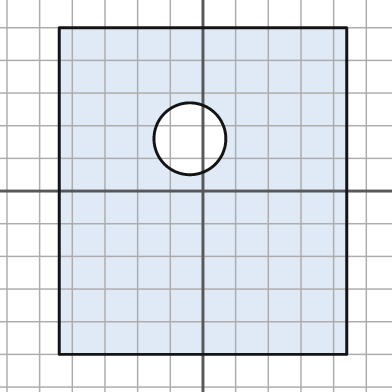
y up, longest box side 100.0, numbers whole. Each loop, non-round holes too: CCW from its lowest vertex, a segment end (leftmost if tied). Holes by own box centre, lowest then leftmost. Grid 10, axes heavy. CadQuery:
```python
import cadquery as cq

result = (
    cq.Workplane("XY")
    .moveTo(-44.0, -50.0)
    .lineTo(44.0, -50.0)
    .lineTo(44.0, 50.0)
    .lineTo(-44.0, 50.0)
    .close()
    .moveTo(-4.0, 16.0)
    .circle(11.0)
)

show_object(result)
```